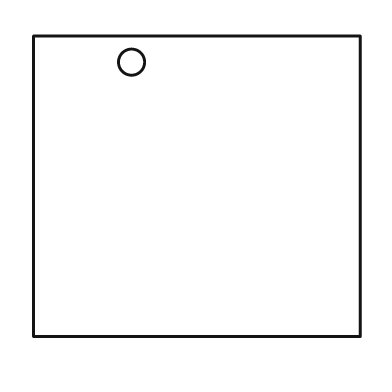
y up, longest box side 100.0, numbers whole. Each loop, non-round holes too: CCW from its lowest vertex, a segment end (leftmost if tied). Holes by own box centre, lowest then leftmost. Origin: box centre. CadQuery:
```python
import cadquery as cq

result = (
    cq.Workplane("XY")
    .moveTo(-50.0, -46.0)
    .lineTo(50.0, -46.0)
    .lineTo(50.0, 46.0)
    .lineTo(-50.0, 46.0)
    .close()
    .moveTo(-20.0, 38.0)
    .circle(4.0)
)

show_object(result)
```